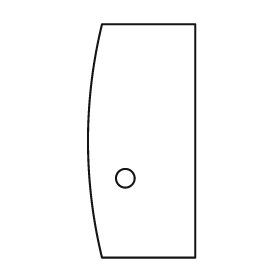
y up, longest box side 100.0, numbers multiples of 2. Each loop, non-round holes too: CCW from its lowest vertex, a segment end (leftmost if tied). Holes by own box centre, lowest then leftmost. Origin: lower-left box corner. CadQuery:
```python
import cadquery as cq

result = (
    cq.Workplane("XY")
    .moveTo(6.0, 0.0)
    .lineTo(46.0, 0.0)
    .lineTo(46.0, 100.0)
    .lineTo(6.0, 100.0)
    .threePointArc((0.0, 50.0), (6.0, 0.0))
    .close()
    .moveTo(16.0, 34.0)
    .circle(4.0)
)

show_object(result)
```